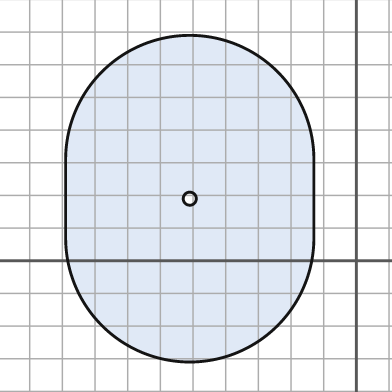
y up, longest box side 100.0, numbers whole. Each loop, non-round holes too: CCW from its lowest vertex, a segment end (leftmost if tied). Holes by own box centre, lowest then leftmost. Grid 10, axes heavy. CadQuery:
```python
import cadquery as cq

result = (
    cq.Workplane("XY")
    .moveTo(-89.0, 7.0)
    .threePointArc((-51.0, -31.0), (-13.0, 7.0))
    .lineTo(-13.0, 31.0)
    .threePointArc((-51.0, 69.0), (-89.0, 31.0))
    .close()
    .moveTo(-51.0, 19.0)
    .circle(2.0)
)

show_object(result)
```